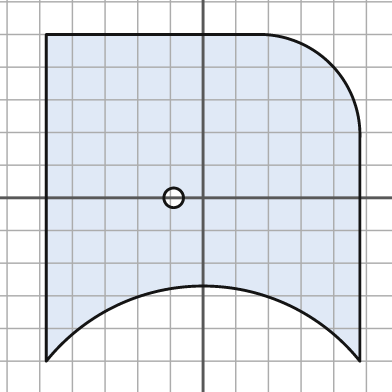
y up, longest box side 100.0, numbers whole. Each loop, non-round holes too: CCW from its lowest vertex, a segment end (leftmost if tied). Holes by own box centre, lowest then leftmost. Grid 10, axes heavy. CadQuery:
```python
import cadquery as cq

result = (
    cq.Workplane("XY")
    .moveTo(-48.0, -50.0)
    .threePointArc((0.0, -27.0), (48.0, -50.0))
    .lineTo(48.0, 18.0)
    .threePointArc((39.0, 41.0), (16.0, 50.0))
    .lineTo(-48.0, 50.0)
    .close()
    .moveTo(-9.0, 0.0)
    .circle(3.0)
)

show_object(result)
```